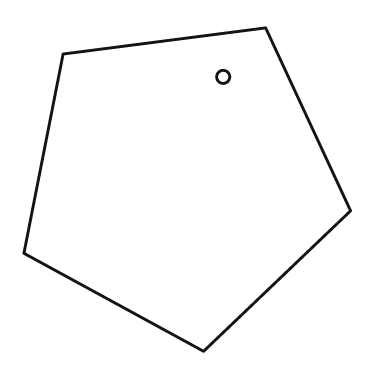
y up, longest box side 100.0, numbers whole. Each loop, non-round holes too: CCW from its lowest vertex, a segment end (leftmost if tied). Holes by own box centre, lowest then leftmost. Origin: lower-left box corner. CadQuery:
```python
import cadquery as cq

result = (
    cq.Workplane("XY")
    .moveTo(55.0, 0.0)
    .lineTo(100.0, 43.0)
    .lineTo(74.0, 99.0)
    .lineTo(12.0, 91.0)
    .lineTo(0.0, 30.0)
    .close()
    .moveTo(61.0, 84.0)
    .circle(2.0)
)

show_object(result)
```